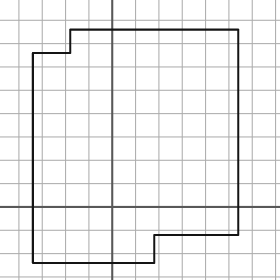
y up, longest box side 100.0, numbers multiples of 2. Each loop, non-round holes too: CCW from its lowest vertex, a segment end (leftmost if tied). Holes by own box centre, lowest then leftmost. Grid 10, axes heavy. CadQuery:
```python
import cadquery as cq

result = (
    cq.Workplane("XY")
    .moveTo(-34.0, -24.0)
    .lineTo(18.0, -24.0)
    .lineTo(18.0, -12.0)
    .lineTo(54.0, -12.0)
    .lineTo(54.0, 76.0)
    .lineTo(-18.0, 76.0)
    .lineTo(-18.0, 66.0)
    .lineTo(-34.0, 66.0)
    .close()
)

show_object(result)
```